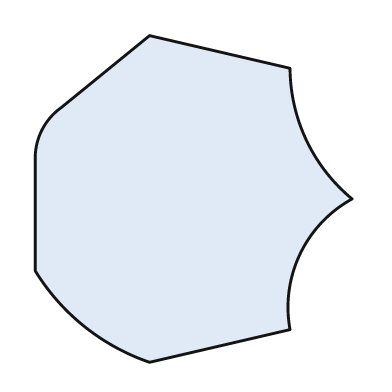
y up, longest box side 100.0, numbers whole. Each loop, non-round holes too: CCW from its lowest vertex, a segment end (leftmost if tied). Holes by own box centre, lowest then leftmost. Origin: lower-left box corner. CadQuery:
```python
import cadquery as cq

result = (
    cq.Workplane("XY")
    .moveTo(35.0, 0.0)
    .lineTo(78.0, 10.0)
    .threePointArc((81.0, 33.0), (97.0, 50.0))
    .threePointArc((83.0, 68.0), (78.0, 90.0))
    .lineTo(35.0, 100.0)
    .lineTo(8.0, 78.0)
    .threePointArc((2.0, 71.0), (0.0, 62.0))
    .lineTo(0.0, 28.0)
    .threePointArc((15.0, 11.0), (35.0, 0.0))
    .close()
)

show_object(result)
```